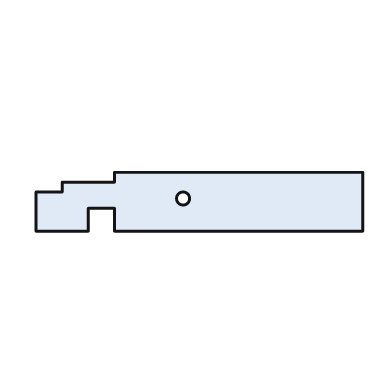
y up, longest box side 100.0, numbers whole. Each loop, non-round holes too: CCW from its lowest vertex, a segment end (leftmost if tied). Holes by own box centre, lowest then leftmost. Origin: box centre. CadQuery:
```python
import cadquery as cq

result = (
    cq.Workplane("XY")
    .moveTo(-50.0, -9.0)
    .lineTo(-34.0, -9.0)
    .lineTo(-34.0, -2.0)
    .lineTo(-26.0, -2.0)
    .lineTo(-26.0, -9.0)
    .lineTo(50.0, -9.0)
    .lineTo(50.0, 9.0)
    .lineTo(-26.0, 9.0)
    .lineTo(-26.0, 6.0)
    .lineTo(-42.0, 6.0)
    .lineTo(-42.0, 3.0)
    .lineTo(-50.0, 3.0)
    .close()
    .moveTo(-5.0, 1.0)
    .circle(2.0)
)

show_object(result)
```